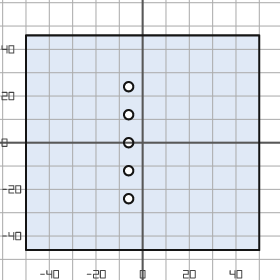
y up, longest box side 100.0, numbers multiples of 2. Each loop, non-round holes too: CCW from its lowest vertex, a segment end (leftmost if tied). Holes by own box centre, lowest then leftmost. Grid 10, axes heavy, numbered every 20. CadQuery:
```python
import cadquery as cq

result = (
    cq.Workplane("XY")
    .moveTo(-50.0, -46.0)
    .lineTo(50.0, -46.0)
    .lineTo(50.0, 46.0)
    .lineTo(-50.0, 46.0)
    .close()
    .moveTo(-6.0, -24.0)
    .circle(2.0)
    .moveTo(-6.0, -12.0)
    .circle(2.0)
    .moveTo(-6.0, 0.0)
    .circle(2.0)
    .moveTo(-6.0, 12.0)
    .circle(2.0)
    .moveTo(-6.0, 24.0)
    .circle(2.0)
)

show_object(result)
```